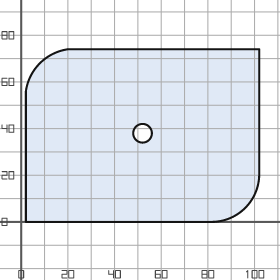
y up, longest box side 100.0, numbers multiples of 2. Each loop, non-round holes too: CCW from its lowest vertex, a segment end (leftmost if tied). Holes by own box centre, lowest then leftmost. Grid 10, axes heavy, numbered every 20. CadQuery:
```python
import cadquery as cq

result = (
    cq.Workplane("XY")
    .moveTo(2.0, 0.0)
    .lineTo(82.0, 0.0)
    .threePointArc((96.0, 6.0), (102.0, 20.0))
    .lineTo(102.0, 74.0)
    .lineTo(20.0, 74.0)
    .threePointArc((8.0, 68.0), (2.0, 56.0))
    .close()
    .moveTo(52.0, 38.0)
    .circle(4.0)
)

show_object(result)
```